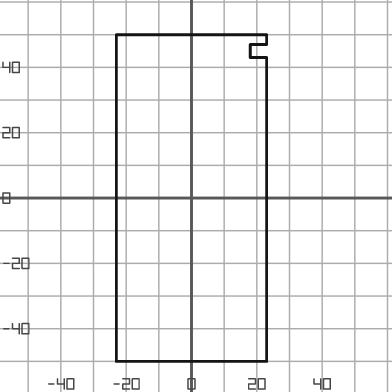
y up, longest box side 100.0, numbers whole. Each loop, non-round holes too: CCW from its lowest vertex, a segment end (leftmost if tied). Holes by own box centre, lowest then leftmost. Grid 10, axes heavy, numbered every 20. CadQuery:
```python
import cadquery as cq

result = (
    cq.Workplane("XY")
    .moveTo(-23.0, -50.0)
    .lineTo(23.0, -50.0)
    .lineTo(23.0, 43.0)
    .lineTo(18.0, 43.0)
    .lineTo(18.0, 47.0)
    .lineTo(23.0, 47.0)
    .lineTo(23.0, 50.0)
    .lineTo(-23.0, 50.0)
    .close()
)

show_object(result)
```